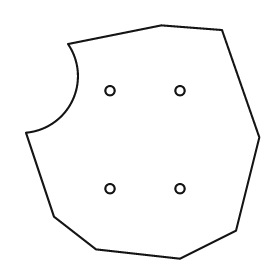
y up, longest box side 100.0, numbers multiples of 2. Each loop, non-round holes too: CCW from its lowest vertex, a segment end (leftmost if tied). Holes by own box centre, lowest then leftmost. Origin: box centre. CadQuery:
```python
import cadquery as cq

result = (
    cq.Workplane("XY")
    .moveTo(16.0, -50.0)
    .lineTo(40.0, -38.0)
    .lineTo(50.0, 2.0)
    .lineTo(34.0, 48.0)
    .lineTo(8.0, 50.0)
    .lineTo(-32.0, 42.0)
    .threePointArc((-30.0, 18.0), (-50.0, 4.0))
    .lineTo(-38.0, -32.0)
    .lineTo(-20.0, -46.0)
    .close()
    .moveTo(-14.0, -20.0)
    .circle(2.0)
    .moveTo(16.0, -20.0)
    .circle(2.0)
    .moveTo(-14.0, 22.0)
    .circle(2.0)
    .moveTo(16.0, 22.0)
    .circle(2.0)
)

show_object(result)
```